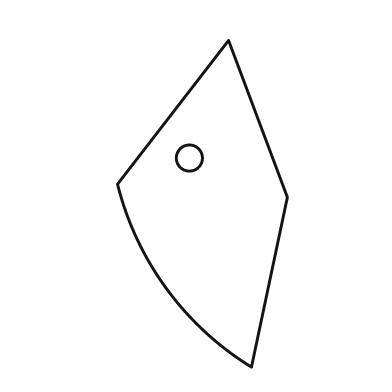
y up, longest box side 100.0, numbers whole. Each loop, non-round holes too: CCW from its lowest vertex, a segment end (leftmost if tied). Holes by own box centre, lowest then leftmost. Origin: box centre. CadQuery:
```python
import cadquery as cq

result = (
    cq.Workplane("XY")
    .moveTo(15.0, -50.0)
    .lineTo(26.0, 2.0)
    .lineTo(8.0, 50.0)
    .lineTo(-26.0, 6.0)
    .threePointArc((-11.0, -26.0), (15.0, -50.0))
    .close()
    .moveTo(-4.0, 14.0)
    .circle(4.0)
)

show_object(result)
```